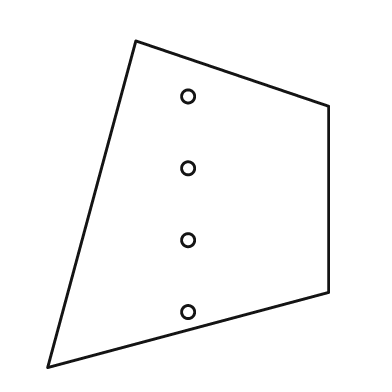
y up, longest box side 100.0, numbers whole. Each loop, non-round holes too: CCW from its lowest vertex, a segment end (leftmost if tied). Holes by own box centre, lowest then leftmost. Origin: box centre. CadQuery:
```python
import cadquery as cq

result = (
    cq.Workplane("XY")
    .moveTo(-43.0, -50.0)
    .lineTo(43.0, -27.0)
    .lineTo(43.0, 30.0)
    .lineTo(-16.0, 50.0)
    .close()
    .moveTo(0.0, -33.0)
    .circle(2.0)
    .moveTo(0.0, -11.0)
    .circle(2.0)
    .moveTo(0.0, 11.0)
    .circle(2.0)
    .moveTo(0.0, 33.0)
    .circle(2.0)
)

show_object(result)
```